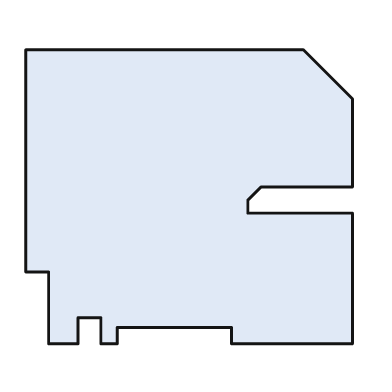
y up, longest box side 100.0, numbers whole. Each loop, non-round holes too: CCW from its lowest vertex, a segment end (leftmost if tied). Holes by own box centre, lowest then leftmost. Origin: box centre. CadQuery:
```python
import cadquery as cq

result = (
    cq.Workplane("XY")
    .moveTo(-43.0, -45.0)
    .lineTo(-34.0, -45.0)
    .lineTo(-34.0, -37.0)
    .lineTo(-27.0, -37.0)
    .lineTo(-27.0, -45.0)
    .lineTo(-22.0, -45.0)
    .lineTo(-22.0, -40.0)
    .lineTo(13.0, -40.0)
    .lineTo(13.0, -45.0)
    .lineTo(50.0, -45.0)
    .lineTo(50.0, -5.0)
    .lineTo(18.0, -5.0)
    .lineTo(18.0, -1.0)
    .lineTo(22.0, 3.0)
    .lineTo(50.0, 3.0)
    .lineTo(50.0, 30.0)
    .lineTo(35.0, 45.0)
    .lineTo(-50.0, 45.0)
    .lineTo(-50.0, -23.0)
    .lineTo(-43.0, -23.0)
    .close()
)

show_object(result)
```